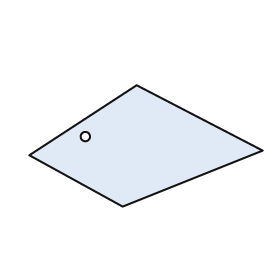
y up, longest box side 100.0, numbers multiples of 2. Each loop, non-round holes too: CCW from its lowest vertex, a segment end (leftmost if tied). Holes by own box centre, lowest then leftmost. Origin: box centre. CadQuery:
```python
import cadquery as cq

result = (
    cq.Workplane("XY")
    .moveTo(-10.0, -26.0)
    .lineTo(50.0, -2.0)
    .lineTo(-4.0, 26.0)
    .lineTo(-50.0, -4.0)
    .close()
    .moveTo(-26.0, 4.0)
    .circle(2.0)
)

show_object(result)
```